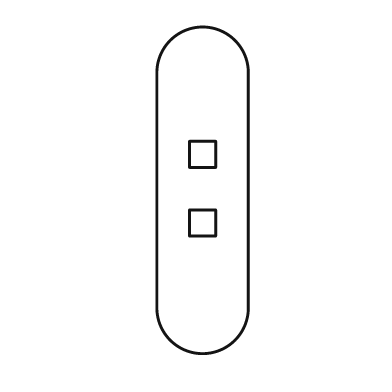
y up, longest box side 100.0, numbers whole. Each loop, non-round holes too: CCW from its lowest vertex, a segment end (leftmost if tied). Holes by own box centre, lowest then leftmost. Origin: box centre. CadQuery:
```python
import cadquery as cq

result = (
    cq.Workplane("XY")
    .moveTo(-14.0, -36.0)
    .threePointArc((0.0, -50.0), (14.0, -36.0))
    .lineTo(14.0, 36.0)
    .threePointArc((0.0, 50.0), (-14.0, 36.0))
    .close()
    .moveTo(-4.0, -14.0)
    .lineTo(4.0, -14.0)
    .lineTo(4.0, -6.0)
    .lineTo(-4.0, -6.0)
    .close()
    .moveTo(-4.0, 7.0)
    .lineTo(4.0, 7.0)
    .lineTo(4.0, 15.0)
    .lineTo(-4.0, 15.0)
    .close()
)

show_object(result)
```